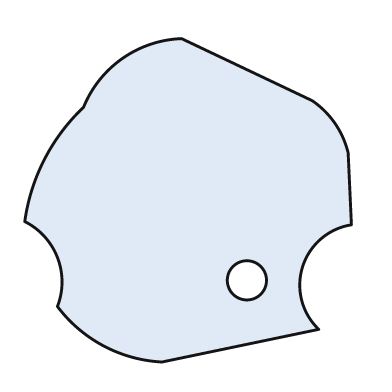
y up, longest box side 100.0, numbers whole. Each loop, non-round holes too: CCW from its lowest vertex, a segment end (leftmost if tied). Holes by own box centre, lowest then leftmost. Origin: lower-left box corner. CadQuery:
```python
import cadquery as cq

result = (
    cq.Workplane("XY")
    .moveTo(42.0, 0.0)
    .lineTo(90.0, 10.0)
    .threePointArc((85.0, 29.0), (100.0, 42.0))
    .lineTo(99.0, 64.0)
    .threePointArc((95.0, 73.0), (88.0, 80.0))
    .lineTo(48.0, 99.0)
    .threePointArc((30.0, 93.0), (18.0, 78.0))
    .threePointArc((6.0, 62.0), (0.0, 43.0))
    .threePointArc((10.0, 32.0), (10.0, 17.0))
    .threePointArc((24.0, 5.0), (42.0, 0.0))
    .close()
    .moveTo(68.0, 25.0)
    .circle(6.0)
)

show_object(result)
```